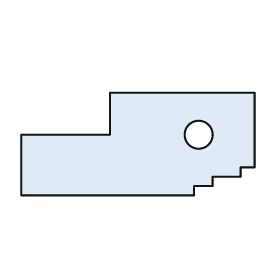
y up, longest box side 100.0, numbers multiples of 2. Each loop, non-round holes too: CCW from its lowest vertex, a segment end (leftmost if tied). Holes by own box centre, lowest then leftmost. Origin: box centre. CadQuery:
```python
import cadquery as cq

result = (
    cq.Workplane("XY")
    .moveTo(-50.0, -22.0)
    .lineTo(24.0, -22.0)
    .lineTo(24.0, -18.0)
    .lineTo(32.0, -18.0)
    .lineTo(32.0, -14.0)
    .lineTo(44.0, -14.0)
    .lineTo(44.0, -10.0)
    .lineTo(50.0, -10.0)
    .lineTo(50.0, 22.0)
    .lineTo(-12.0, 22.0)
    .lineTo(-12.0, 4.0)
    .lineTo(-50.0, 4.0)
    .close()
    .moveTo(26.0, 4.0)
    .circle(6.0)
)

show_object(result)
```